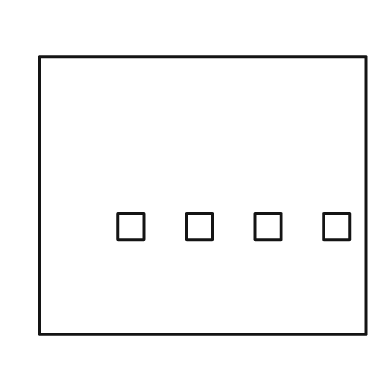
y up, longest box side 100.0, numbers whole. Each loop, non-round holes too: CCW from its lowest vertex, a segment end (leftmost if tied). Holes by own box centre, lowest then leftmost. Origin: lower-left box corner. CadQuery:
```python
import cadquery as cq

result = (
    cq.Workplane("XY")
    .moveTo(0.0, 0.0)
    .lineTo(100.0, 0.0)
    .lineTo(100.0, 85.0)
    .lineTo(0.0, 85.0)
    .close()
    .moveTo(24.0, 29.0)
    .lineTo(32.0, 29.0)
    .lineTo(32.0, 37.0)
    .lineTo(24.0, 37.0)
    .close()
    .moveTo(45.0, 29.0)
    .lineTo(53.0, 29.0)
    .lineTo(53.0, 37.0)
    .lineTo(45.0, 37.0)
    .close()
    .moveTo(66.0, 29.0)
    .lineTo(74.0, 29.0)
    .lineTo(74.0, 37.0)
    .lineTo(66.0, 37.0)
    .close()
    .moveTo(87.0, 29.0)
    .lineTo(95.0, 29.0)
    .lineTo(95.0, 37.0)
    .lineTo(87.0, 37.0)
    .close()
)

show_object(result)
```